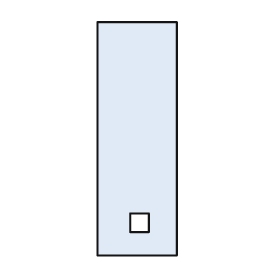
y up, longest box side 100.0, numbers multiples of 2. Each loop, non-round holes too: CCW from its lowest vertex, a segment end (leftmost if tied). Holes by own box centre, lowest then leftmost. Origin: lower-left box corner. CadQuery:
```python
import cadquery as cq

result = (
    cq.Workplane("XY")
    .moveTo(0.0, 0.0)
    .lineTo(34.0, 0.0)
    .lineTo(34.0, 100.0)
    .lineTo(0.0, 100.0)
    .close()
    .moveTo(14.0, 10.0)
    .lineTo(22.0, 10.0)
    .lineTo(22.0, 18.0)
    .lineTo(14.0, 18.0)
    .close()
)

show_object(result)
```